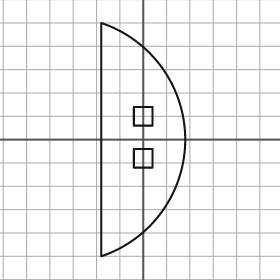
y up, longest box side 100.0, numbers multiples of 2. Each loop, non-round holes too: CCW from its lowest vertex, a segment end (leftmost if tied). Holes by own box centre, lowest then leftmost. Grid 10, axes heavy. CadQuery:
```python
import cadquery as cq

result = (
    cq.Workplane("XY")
    .moveTo(-18.0, -50.0)
    .threePointArc((18.0, 0.0), (-18.0, 50.0))
    .close()
    .moveTo(-4.0, -12.0)
    .lineTo(4.0, -12.0)
    .lineTo(4.0, -4.0)
    .lineTo(-4.0, -4.0)
    .close()
    .moveTo(-4.0, 6.0)
    .lineTo(4.0, 6.0)
    .lineTo(4.0, 14.0)
    .lineTo(-4.0, 14.0)
    .close()
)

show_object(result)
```